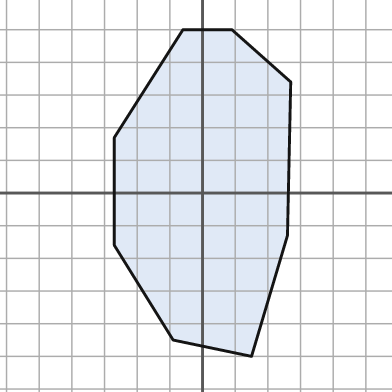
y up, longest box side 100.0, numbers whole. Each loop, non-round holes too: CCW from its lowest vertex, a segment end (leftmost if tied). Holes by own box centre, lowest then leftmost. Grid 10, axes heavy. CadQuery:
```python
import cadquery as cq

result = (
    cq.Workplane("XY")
    .moveTo(15.0, -50.0)
    .lineTo(26.0, -13.0)
    .lineTo(27.0, 34.0)
    .lineTo(9.0, 50.0)
    .lineTo(-6.0, 50.0)
    .lineTo(-27.0, 17.0)
    .lineTo(-27.0, -16.0)
    .lineTo(-9.0, -45.0)
    .close()
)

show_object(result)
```